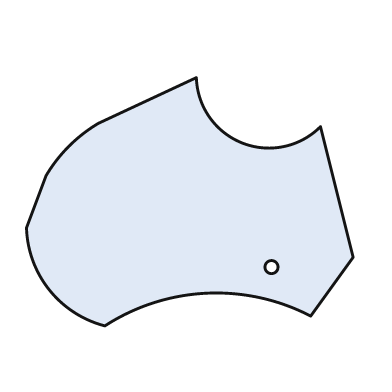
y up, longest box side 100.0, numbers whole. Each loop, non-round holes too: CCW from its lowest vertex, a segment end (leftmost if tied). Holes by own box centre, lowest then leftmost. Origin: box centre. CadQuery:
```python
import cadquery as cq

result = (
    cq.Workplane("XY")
    .moveTo(-26.0, -38.0)
    .threePointArc((5.0, -28.0), (37.0, -35.0))
    .lineTo(50.0, -17.0)
    .lineTo(40.0, 23.0)
    .threePointArc((16.0, 18.0), (2.0, 38.0))
    .lineTo(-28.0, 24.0)
    .threePointArc((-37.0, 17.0), (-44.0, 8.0))
    .lineTo(-50.0, -8.0)
    .threePointArc((-43.0, -27.0), (-26.0, -38.0))
    .close()
    .moveTo(25.0, -20.0)
    .circle(2.0)
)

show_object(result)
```